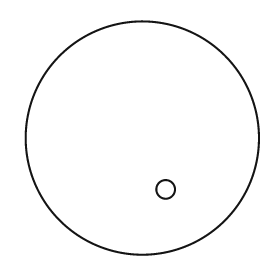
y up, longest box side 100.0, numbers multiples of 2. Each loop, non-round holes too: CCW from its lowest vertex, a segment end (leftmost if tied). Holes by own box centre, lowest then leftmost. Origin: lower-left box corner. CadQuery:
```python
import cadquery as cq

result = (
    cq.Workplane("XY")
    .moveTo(50.0, 50.0)
    .circle(50.0)
    .moveTo(60.0, 28.0)
    .circle(4.0)
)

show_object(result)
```